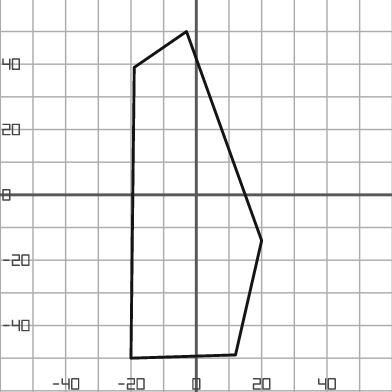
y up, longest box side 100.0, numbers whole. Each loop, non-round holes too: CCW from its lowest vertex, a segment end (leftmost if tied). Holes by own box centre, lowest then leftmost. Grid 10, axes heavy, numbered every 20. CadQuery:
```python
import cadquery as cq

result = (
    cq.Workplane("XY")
    .moveTo(-20.0, -50.0)
    .lineTo(12.0, -49.0)
    .lineTo(20.0, -14.0)
    .lineTo(-3.0, 50.0)
    .lineTo(-19.0, 39.0)
    .close()
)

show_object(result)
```